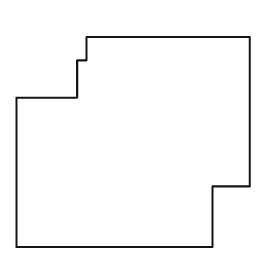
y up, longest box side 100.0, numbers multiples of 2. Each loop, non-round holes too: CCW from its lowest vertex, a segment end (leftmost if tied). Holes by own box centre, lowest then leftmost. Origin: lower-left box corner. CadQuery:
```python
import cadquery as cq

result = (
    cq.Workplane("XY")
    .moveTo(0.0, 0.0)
    .lineTo(84.0, 0.0)
    .lineTo(84.0, 26.0)
    .lineTo(100.0, 26.0)
    .lineTo(100.0, 90.0)
    .lineTo(30.0, 90.0)
    .lineTo(30.0, 80.0)
    .lineTo(26.0, 80.0)
    .lineTo(26.0, 64.0)
    .lineTo(0.0, 64.0)
    .close()
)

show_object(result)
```